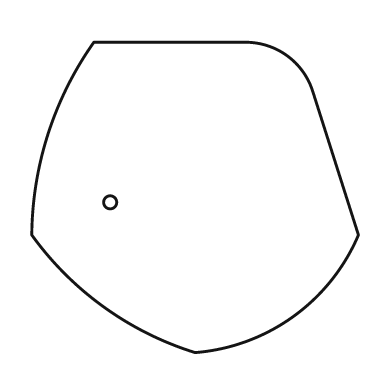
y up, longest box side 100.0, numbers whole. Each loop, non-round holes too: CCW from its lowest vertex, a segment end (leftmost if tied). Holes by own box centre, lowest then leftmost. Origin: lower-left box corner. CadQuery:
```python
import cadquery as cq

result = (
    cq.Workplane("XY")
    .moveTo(50.0, 0.0)
    .threePointArc((80.0, 11.0), (100.0, 36.0))
    .lineTo(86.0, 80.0)
    .threePointArc((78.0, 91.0), (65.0, 95.0))
    .lineTo(19.0, 95.0)
    .threePointArc((5.0, 67.0), (0.0, 36.0))
    .threePointArc((22.0, 14.0), (50.0, 0.0))
    .close()
    .moveTo(24.0, 46.0)
    .circle(2.0)
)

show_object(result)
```